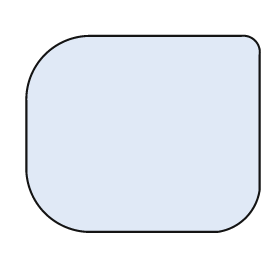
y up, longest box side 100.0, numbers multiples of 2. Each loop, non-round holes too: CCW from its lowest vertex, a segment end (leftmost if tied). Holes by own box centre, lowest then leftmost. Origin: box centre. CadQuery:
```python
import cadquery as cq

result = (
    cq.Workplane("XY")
    .moveTo(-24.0, -42.0)
    .lineTo(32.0, -42.0)
    .threePointArc((44.0, -36.0), (50.0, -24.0))
    .lineTo(50.0, 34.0)
    .threePointArc((48.0, 40.0), (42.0, 42.0))
    .lineTo(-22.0, 42.0)
    .threePointArc((-42.0, 34.0), (-50.0, 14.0))
    .lineTo(-50.0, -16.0)
    .threePointArc((-42.0, -34.0), (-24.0, -42.0))
    .close()
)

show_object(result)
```